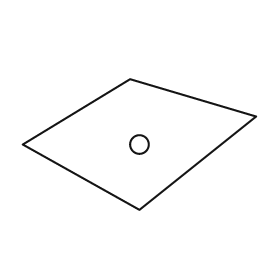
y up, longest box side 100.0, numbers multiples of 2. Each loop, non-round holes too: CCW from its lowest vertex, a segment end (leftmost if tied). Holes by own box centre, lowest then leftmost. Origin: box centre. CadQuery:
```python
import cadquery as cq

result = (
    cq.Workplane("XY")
    .moveTo(0.0, -28.0)
    .lineTo(50.0, 12.0)
    .lineTo(-4.0, 28.0)
    .lineTo(-50.0, 0.0)
    .close()
    .moveTo(0.0, 0.0)
    .circle(4.0)
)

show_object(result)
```